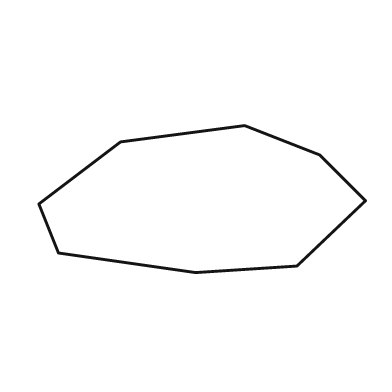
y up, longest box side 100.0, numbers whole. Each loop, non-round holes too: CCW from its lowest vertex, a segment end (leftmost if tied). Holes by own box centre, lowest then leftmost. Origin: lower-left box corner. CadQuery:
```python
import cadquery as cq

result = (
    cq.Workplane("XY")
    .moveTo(48.0, 0.0)
    .lineTo(79.0, 2.0)
    .lineTo(100.0, 22.0)
    .lineTo(86.0, 36.0)
    .lineTo(63.0, 45.0)
    .lineTo(25.0, 40.0)
    .lineTo(0.0, 21.0)
    .lineTo(6.0, 6.0)
    .close()
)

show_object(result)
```